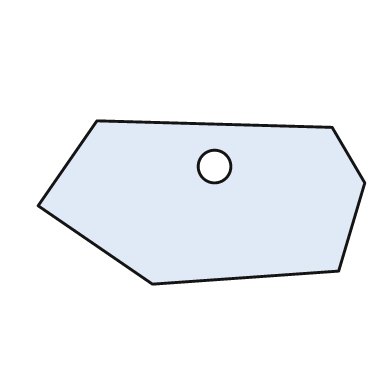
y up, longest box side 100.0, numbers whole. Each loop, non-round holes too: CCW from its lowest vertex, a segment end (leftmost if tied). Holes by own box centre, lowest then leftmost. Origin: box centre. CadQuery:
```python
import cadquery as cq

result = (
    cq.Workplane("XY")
    .moveTo(-15.0, -25.0)
    .lineTo(42.0, -21.0)
    .lineTo(50.0, 6.0)
    .lineTo(40.0, 23.0)
    .lineTo(-32.0, 25.0)
    .lineTo(-50.0, -1.0)
    .close()
    .moveTo(4.0, 11.0)
    .circle(5.0)
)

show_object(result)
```